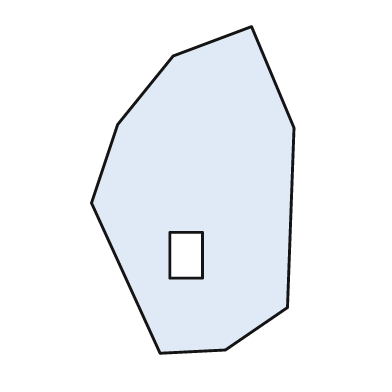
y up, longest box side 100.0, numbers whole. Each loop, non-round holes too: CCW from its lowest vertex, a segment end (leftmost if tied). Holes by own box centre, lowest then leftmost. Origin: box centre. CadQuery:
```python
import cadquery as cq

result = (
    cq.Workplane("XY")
    .moveTo(-10.0, -50.0)
    .lineTo(10.0, -49.0)
    .lineTo(29.0, -36.0)
    .lineTo(31.0, 19.0)
    .lineTo(18.0, 50.0)
    .lineTo(-6.0, 41.0)
    .lineTo(-23.0, 20.0)
    .lineTo(-31.0, -4.0)
    .close()
    .moveTo(-7.0, -27.0)
    .lineTo(3.0, -27.0)
    .lineTo(3.0, -13.0)
    .lineTo(-7.0, -13.0)
    .close()
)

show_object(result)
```